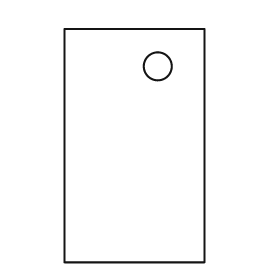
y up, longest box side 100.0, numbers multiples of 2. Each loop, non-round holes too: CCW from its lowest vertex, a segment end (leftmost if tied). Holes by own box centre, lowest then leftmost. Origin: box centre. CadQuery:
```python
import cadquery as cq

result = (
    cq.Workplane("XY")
    .moveTo(-30.0, -50.0)
    .lineTo(30.0, -50.0)
    .lineTo(30.0, 50.0)
    .lineTo(-30.0, 50.0)
    .close()
    .moveTo(10.0, 34.0)
    .circle(6.0)
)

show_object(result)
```